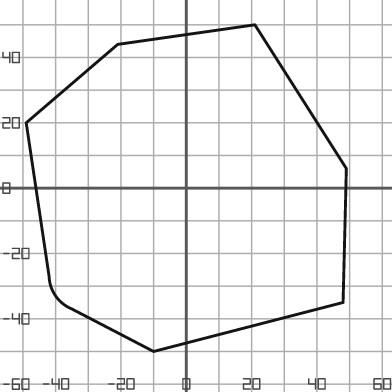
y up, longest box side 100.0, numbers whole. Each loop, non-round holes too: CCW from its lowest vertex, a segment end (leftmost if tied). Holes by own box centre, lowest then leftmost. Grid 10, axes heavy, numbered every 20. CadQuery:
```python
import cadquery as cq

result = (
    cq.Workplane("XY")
    .moveTo(-10.0, -50.0)
    .lineTo(48.0, -35.0)
    .lineTo(49.0, 6.0)
    .lineTo(21.0, 50.0)
    .lineTo(-21.0, 44.0)
    .lineTo(-49.0, 20.0)
    .lineTo(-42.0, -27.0)
    .threePointArc((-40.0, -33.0), (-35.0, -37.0))
    .close()
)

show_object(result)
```